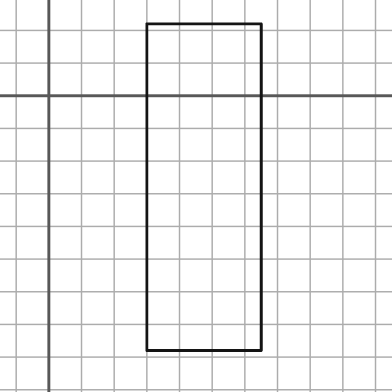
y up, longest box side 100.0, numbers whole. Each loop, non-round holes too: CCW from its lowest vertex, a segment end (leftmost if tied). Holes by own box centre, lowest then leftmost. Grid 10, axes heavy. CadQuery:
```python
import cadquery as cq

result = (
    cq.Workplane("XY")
    .moveTo(30.0, -78.0)
    .lineTo(65.0, -78.0)
    .lineTo(65.0, 22.0)
    .lineTo(30.0, 22.0)
    .close()
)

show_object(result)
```